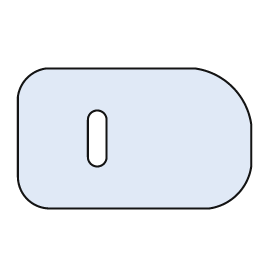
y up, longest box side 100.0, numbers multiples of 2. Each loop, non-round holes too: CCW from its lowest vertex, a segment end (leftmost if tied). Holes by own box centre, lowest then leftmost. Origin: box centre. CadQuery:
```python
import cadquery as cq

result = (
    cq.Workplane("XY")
    .moveTo(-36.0, -30.0)
    .lineTo(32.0, -30.0)
    .threePointArc((44.0, -24.0), (50.0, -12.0))
    .lineTo(50.0, 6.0)
    .threePointArc((42.0, 22.0), (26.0, 30.0))
    .lineTo(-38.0, 30.0)
    .threePointArc((-46.0, 26.0), (-50.0, 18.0))
    .lineTo(-50.0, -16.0)
    .threePointArc((-46.0, -26.0), (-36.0, -30.0))
    .close()
    .moveTo(-20.0, -8.0)
    .threePointArc((-16.0, -12.0), (-12.0, -8.0))
    .lineTo(-12.0, 8.0)
    .threePointArc((-16.0, 12.0), (-20.0, 8.0))
    .close()
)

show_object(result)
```